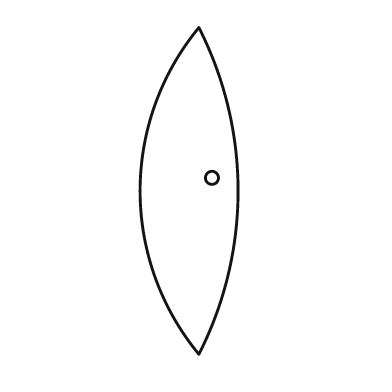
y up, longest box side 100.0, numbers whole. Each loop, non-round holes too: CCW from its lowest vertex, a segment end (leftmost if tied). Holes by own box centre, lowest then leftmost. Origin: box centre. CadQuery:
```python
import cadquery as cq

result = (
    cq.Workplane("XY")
    .moveTo(3.0, -50.0)
    .threePointArc((15.0, 0.0), (3.0, 50.0))
    .threePointArc((-15.0, 0.0), (3.0, -50.0))
    .close()
    .moveTo(7.0, 4.0)
    .circle(2.0)
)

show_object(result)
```